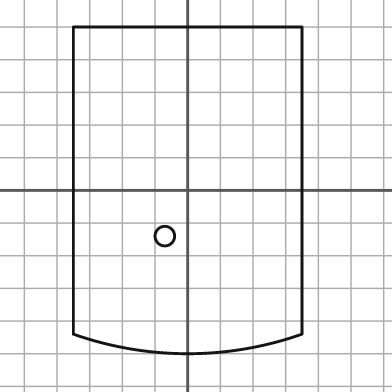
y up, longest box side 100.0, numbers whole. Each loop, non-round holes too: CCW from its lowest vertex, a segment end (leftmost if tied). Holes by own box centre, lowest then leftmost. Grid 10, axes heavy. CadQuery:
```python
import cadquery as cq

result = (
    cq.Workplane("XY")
    .moveTo(-35.0, -44.0)
    .threePointArc((0.0, -50.0), (35.0, -44.0))
    .lineTo(35.0, 50.0)
    .lineTo(-35.0, 50.0)
    .close()
    .moveTo(-7.0, -14.0)
    .circle(3.0)
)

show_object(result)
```